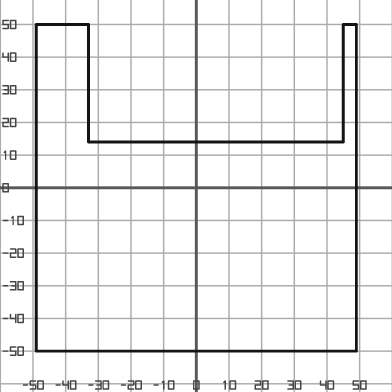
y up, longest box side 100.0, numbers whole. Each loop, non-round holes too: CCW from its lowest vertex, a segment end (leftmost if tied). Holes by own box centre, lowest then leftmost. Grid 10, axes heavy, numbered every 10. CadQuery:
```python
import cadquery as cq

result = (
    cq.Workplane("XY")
    .moveTo(-49.0, -50.0)
    .lineTo(49.0, -50.0)
    .lineTo(49.0, 50.0)
    .lineTo(45.0, 50.0)
    .lineTo(45.0, 14.0)
    .lineTo(-33.0, 14.0)
    .lineTo(-33.0, 50.0)
    .lineTo(-49.0, 50.0)
    .close()
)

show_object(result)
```